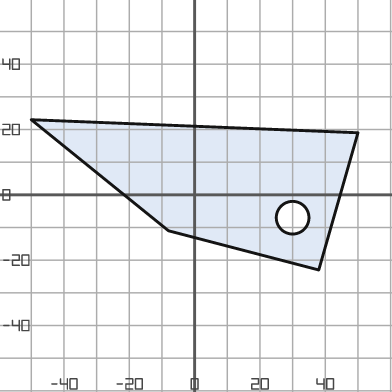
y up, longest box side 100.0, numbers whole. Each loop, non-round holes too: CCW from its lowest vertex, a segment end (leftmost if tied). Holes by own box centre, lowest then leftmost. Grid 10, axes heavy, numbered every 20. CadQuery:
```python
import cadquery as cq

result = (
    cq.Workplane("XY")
    .moveTo(38.0, -23.0)
    .lineTo(50.0, 19.0)
    .lineTo(-50.0, 23.0)
    .lineTo(-8.0, -11.0)
    .close()
    .moveTo(30.0, -7.0)
    .circle(5.0)
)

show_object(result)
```